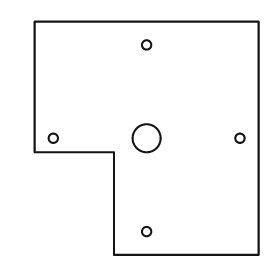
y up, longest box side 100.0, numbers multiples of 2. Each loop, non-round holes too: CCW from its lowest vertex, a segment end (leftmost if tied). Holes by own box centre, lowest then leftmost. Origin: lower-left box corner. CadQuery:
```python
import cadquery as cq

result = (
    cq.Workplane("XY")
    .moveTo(34.0, 0.0)
    .lineTo(96.0, 0.0)
    .lineTo(96.0, 100.0)
    .lineTo(0.0, 100.0)
    .lineTo(0.0, 44.0)
    .lineTo(34.0, 44.0)
    .close()
    .moveTo(48.0, 10.0)
    .circle(2.0)
    .moveTo(8.0, 50.0)
    .circle(2.0)
    .moveTo(48.0, 50.0)
    .circle(6.0)
    .moveTo(88.0, 50.0)
    .circle(2.0)
    .moveTo(48.0, 90.0)
    .circle(2.0)
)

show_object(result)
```